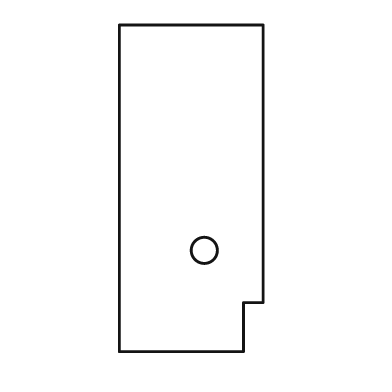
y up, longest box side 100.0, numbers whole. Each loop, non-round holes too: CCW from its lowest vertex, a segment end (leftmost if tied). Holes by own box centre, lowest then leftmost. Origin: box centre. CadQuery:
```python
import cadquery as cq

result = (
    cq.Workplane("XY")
    .moveTo(-22.0, -50.0)
    .lineTo(16.0, -50.0)
    .lineTo(16.0, -35.0)
    .lineTo(22.0, -35.0)
    .lineTo(22.0, 50.0)
    .lineTo(-22.0, 50.0)
    .close()
    .moveTo(4.0, -19.0)
    .circle(4.0)
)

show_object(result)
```